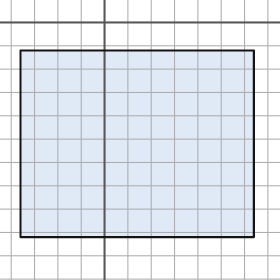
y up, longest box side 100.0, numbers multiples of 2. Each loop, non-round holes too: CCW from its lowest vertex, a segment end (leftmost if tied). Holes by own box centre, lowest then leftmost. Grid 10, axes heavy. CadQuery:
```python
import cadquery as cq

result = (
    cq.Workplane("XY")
    .moveTo(-36.0, -92.0)
    .lineTo(64.0, -92.0)
    .lineTo(64.0, -12.0)
    .lineTo(-36.0, -12.0)
    .close()
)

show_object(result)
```